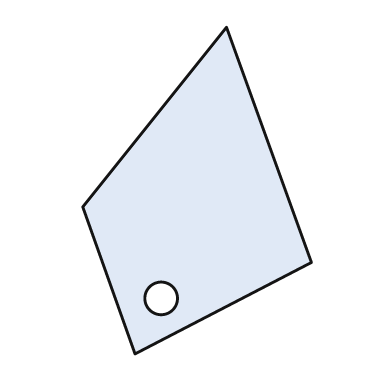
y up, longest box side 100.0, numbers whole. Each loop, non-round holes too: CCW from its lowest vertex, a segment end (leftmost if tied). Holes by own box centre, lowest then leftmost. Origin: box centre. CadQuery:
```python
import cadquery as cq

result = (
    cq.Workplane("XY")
    .moveTo(-19.0, -50.0)
    .lineTo(35.0, -22.0)
    .lineTo(9.0, 50.0)
    .lineTo(-35.0, -5.0)
    .close()
    .moveTo(-11.0, -33.0)
    .circle(5.0)
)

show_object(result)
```